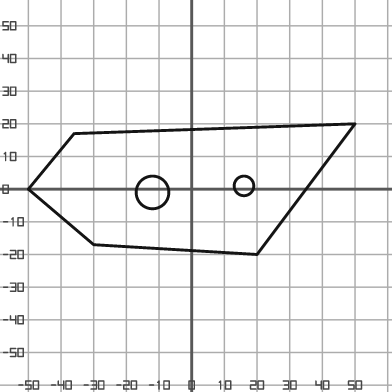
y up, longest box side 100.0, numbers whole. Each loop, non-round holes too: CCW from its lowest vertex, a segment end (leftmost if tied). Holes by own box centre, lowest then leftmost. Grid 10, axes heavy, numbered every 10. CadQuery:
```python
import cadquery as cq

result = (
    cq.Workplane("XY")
    .moveTo(20.0, -20.0)
    .lineTo(50.0, 20.0)
    .lineTo(-36.0, 17.0)
    .lineTo(-50.0, 0.0)
    .lineTo(-30.0, -17.0)
    .close()
    .moveTo(-12.0, -1.0)
    .circle(5.0)
    .moveTo(16.0, 1.0)
    .circle(3.0)
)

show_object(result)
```